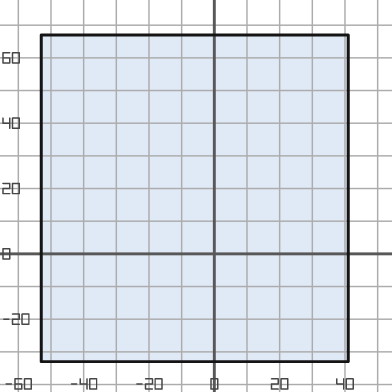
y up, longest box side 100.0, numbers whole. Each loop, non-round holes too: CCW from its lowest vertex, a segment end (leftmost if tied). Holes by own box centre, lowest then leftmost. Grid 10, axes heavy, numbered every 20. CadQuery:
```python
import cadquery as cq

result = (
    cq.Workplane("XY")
    .moveTo(-53.0, -33.0)
    .lineTo(41.0, -33.0)
    .lineTo(41.0, 67.0)
    .lineTo(-53.0, 67.0)
    .close()
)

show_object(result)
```